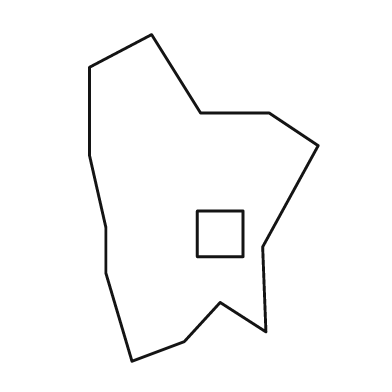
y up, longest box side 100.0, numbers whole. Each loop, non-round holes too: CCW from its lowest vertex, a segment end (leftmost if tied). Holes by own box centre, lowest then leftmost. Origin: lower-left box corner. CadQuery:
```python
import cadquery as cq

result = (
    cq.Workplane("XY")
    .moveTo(13.0, 0.0)
    .lineTo(29.0, 6.0)
    .lineTo(40.0, 18.0)
    .lineTo(54.0, 9.0)
    .lineTo(53.0, 35.0)
    .lineTo(70.0, 66.0)
    .lineTo(55.0, 76.0)
    .lineTo(34.0, 76.0)
    .lineTo(19.0, 100.0)
    .lineTo(0.0, 90.0)
    .lineTo(0.0, 63.0)
    .lineTo(5.0, 41.0)
    .lineTo(5.0, 27.0)
    .close()
    .moveTo(33.0, 32.0)
    .lineTo(47.0, 32.0)
    .lineTo(47.0, 46.0)
    .lineTo(33.0, 46.0)
    .close()
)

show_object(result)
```